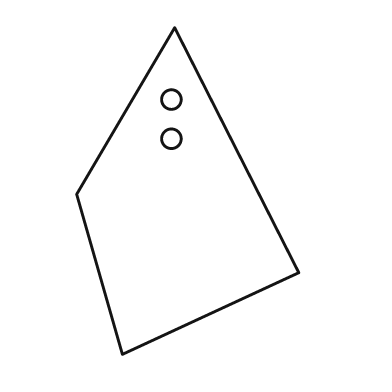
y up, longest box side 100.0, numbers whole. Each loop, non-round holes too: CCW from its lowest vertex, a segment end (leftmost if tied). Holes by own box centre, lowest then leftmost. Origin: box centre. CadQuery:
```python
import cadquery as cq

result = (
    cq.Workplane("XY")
    .moveTo(-20.0, -50.0)
    .lineTo(34.0, -25.0)
    .lineTo(-4.0, 50.0)
    .lineTo(-34.0, -1.0)
    .close()
    .moveTo(-5.0, 16.0)
    .circle(3.0)
    .moveTo(-5.0, 28.0)
    .circle(3.0)
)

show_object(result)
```